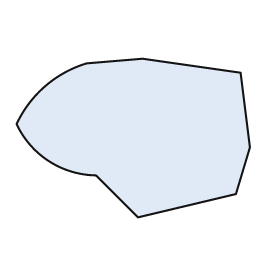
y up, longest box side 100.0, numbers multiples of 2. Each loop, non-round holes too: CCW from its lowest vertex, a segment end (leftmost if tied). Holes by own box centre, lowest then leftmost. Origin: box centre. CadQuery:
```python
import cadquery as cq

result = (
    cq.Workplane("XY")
    .moveTo(2.0, -34.0)
    .lineTo(44.0, -24.0)
    .lineTo(50.0, -4.0)
    .lineTo(46.0, 28.0)
    .lineTo(4.0, 34.0)
    .lineTo(-20.0, 32.0)
    .threePointArc((-38.0, 22.0), (-50.0, 6.0))
    .threePointArc((-36.0, -10.0), (-16.0, -16.0))
    .close()
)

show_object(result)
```